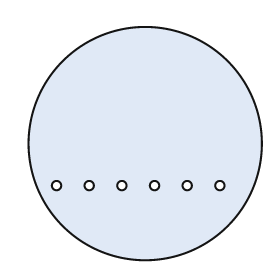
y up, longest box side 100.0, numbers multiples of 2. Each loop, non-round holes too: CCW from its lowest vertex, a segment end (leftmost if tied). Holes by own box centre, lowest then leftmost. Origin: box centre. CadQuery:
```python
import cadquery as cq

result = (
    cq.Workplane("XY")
    .moveTo(0.0, 0.0)
    .circle(50.0)
    .moveTo(-38.0, -18.0)
    .circle(2.0)
    .moveTo(-24.0, -18.0)
    .circle(2.0)
    .moveTo(-10.0, -18.0)
    .circle(2.0)
    .moveTo(4.0, -18.0)
    .circle(2.0)
    .moveTo(18.0, -18.0)
    .circle(2.0)
    .moveTo(32.0, -18.0)
    .circle(2.0)
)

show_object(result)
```